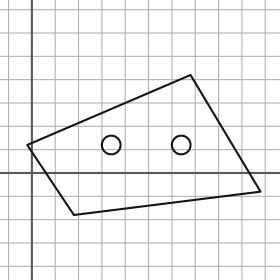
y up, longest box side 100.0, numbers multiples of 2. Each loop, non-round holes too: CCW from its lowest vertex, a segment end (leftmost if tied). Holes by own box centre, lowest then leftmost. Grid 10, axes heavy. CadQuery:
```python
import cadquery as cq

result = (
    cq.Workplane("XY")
    .moveTo(18.0, -18.0)
    .lineTo(98.0, -8.0)
    .lineTo(68.0, 42.0)
    .lineTo(-2.0, 12.0)
    .close()
    .moveTo(34.0, 12.0)
    .circle(4.0)
    .moveTo(64.0, 12.0)
    .circle(4.0)
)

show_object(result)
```